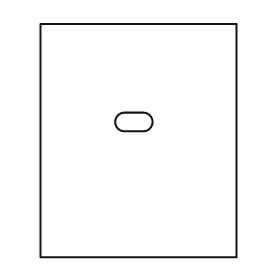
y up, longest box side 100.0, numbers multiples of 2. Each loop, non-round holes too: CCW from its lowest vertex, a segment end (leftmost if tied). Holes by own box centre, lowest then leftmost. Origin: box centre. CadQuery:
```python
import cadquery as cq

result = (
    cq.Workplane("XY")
    .moveTo(-42.0, -50.0)
    .lineTo(42.0, -50.0)
    .lineTo(42.0, 50.0)
    .lineTo(-42.0, 50.0)
    .close()
    .moveTo(-6.0, 4.0)
    .lineTo(2.0, 4.0)
    .threePointArc((6.0, 8.0), (2.0, 12.0))
    .lineTo(-6.0, 12.0)
    .threePointArc((-10.0, 8.0), (-6.0, 4.0))
    .close()
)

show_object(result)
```